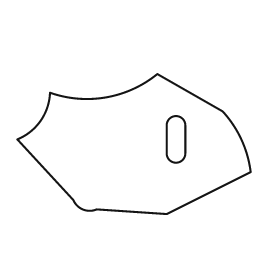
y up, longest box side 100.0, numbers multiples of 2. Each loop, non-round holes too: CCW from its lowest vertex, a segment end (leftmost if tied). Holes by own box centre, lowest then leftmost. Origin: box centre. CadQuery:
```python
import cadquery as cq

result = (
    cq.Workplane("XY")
    .moveTo(14.0, -30.0)
    .lineTo(50.0, -12.0)
    .threePointArc((46.0, 2.0), (38.0, 14.0))
    .lineTo(10.0, 30.0)
    .threePointArc((-12.0, 20.0), (-36.0, 22.0))
    .threePointArc((-40.0, 10.0), (-50.0, 2.0))
    .lineTo(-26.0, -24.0)
    .threePointArc((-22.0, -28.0), (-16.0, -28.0))
    .close()
    .moveTo(14.0, -4.0)
    .threePointArc((18.0, -8.0), (22.0, -4.0))
    .lineTo(22.0, 8.0)
    .threePointArc((18.0, 12.0), (14.0, 8.0))
    .close()
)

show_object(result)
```